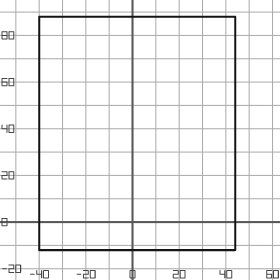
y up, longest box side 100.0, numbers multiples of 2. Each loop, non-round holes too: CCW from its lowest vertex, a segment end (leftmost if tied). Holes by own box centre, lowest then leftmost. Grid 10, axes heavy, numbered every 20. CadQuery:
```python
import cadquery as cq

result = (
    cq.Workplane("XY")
    .moveTo(-40.0, -12.0)
    .lineTo(44.0, -12.0)
    .lineTo(44.0, 88.0)
    .lineTo(-40.0, 88.0)
    .close()
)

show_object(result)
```